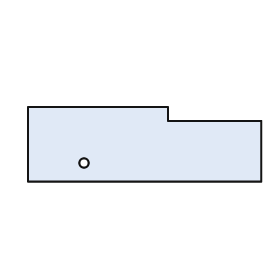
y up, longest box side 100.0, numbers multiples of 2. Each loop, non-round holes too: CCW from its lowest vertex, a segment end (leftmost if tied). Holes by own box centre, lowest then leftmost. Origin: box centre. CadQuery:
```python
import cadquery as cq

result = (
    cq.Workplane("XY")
    .moveTo(-50.0, -16.0)
    .lineTo(50.0, -16.0)
    .lineTo(50.0, 10.0)
    .lineTo(10.0, 10.0)
    .lineTo(10.0, 16.0)
    .lineTo(-50.0, 16.0)
    .close()
    .moveTo(-26.0, -8.0)
    .circle(2.0)
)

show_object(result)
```